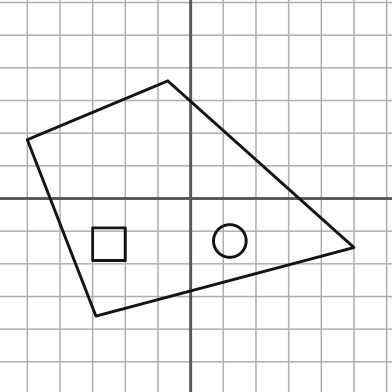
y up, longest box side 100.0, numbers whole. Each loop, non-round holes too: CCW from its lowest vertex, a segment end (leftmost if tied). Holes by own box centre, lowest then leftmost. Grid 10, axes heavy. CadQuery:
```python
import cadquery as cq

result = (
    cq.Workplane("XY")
    .moveTo(-29.0, -36.0)
    .lineTo(50.0, -15.0)
    .lineTo(-7.0, 36.0)
    .lineTo(-50.0, 18.0)
    .close()
    .moveTo(-30.0, -19.0)
    .lineTo(-20.0, -19.0)
    .lineTo(-20.0, -9.0)
    .lineTo(-30.0, -9.0)
    .close()
    .moveTo(12.0, -13.0)
    .circle(5.0)
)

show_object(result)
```